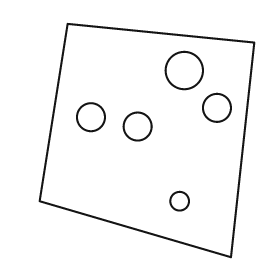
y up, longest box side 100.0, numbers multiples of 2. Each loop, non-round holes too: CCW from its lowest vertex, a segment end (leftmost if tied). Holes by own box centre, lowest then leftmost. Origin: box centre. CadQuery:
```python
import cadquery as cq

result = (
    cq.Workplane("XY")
    .moveTo(36.0, -50.0)
    .lineTo(46.0, 42.0)
    .lineTo(-34.0, 50.0)
    .lineTo(-46.0, -26.0)
    .close()
    .moveTo(14.0, -26.0)
    .circle(4.0)
    .moveTo(-4.0, 6.0)
    .circle(6.0)
    .moveTo(-24.0, 10.0)
    .circle(6.0)
    .moveTo(30.0, 14.0)
    .circle(6.0)
    .moveTo(16.0, 30.0)
    .circle(8.0)
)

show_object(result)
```